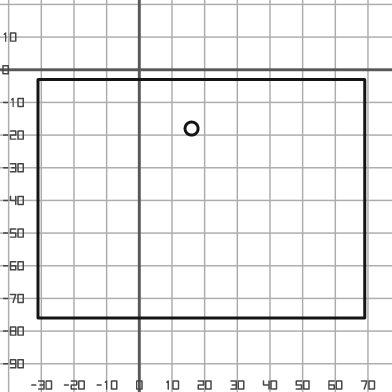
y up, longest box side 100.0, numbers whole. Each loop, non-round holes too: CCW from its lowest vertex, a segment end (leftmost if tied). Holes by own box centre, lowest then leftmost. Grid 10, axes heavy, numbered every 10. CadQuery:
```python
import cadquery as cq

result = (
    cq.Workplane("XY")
    .moveTo(-31.0, -76.0)
    .lineTo(69.0, -76.0)
    .lineTo(69.0, -3.0)
    .lineTo(-31.0, -3.0)
    .close()
    .moveTo(16.0, -18.0)
    .circle(2.0)
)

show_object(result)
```